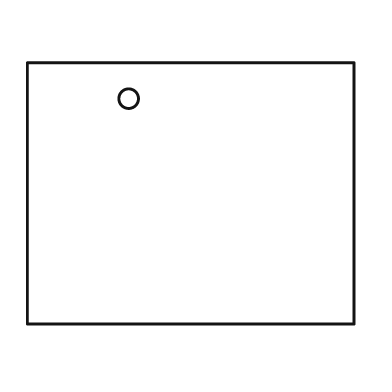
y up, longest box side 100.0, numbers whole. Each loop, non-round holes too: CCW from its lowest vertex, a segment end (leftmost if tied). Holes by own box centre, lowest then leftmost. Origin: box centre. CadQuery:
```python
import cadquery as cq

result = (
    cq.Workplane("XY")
    .moveTo(-50.0, -40.0)
    .lineTo(50.0, -40.0)
    .lineTo(50.0, 40.0)
    .lineTo(-50.0, 40.0)
    .close()
    .moveTo(-19.0, 29.0)
    .circle(3.0)
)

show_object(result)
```